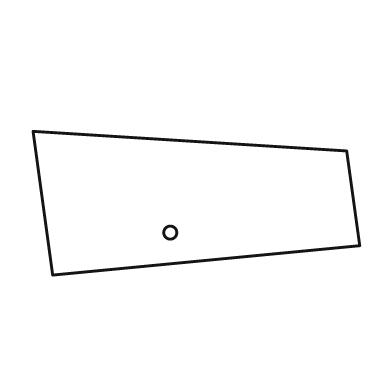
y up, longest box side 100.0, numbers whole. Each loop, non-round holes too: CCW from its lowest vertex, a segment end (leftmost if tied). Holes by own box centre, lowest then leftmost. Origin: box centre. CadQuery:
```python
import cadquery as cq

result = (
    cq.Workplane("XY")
    .moveTo(-44.0, -22.0)
    .lineTo(50.0, -13.0)
    .lineTo(46.0, 16.0)
    .lineTo(-50.0, 22.0)
    .close()
    .moveTo(-8.0, -9.0)
    .circle(2.0)
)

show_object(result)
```